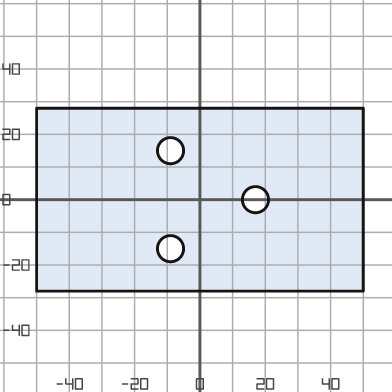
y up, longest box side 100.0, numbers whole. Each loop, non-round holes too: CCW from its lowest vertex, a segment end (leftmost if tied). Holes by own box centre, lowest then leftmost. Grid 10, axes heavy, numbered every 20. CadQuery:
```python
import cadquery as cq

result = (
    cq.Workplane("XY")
    .moveTo(-50.0, -28.0)
    .lineTo(50.0, -28.0)
    .lineTo(50.0, 28.0)
    .lineTo(-50.0, 28.0)
    .close()
    .moveTo(-9.0, -15.0)
    .circle(4.0)
    .moveTo(17.0, 0.0)
    .circle(4.0)
    .moveTo(-9.0, 15.0)
    .circle(4.0)
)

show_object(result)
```